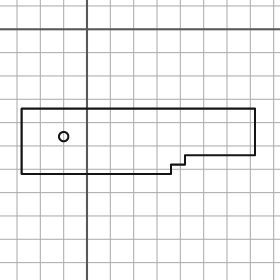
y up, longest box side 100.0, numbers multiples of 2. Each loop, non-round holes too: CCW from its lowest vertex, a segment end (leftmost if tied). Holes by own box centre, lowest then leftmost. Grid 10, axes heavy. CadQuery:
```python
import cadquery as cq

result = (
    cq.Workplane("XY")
    .moveTo(-28.0, -62.0)
    .lineTo(36.0, -62.0)
    .lineTo(36.0, -58.0)
    .lineTo(42.0, -58.0)
    .lineTo(42.0, -54.0)
    .lineTo(72.0, -54.0)
    .lineTo(72.0, -34.0)
    .lineTo(-28.0, -34.0)
    .close()
    .moveTo(-10.0, -46.0)
    .circle(2.0)
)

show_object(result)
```